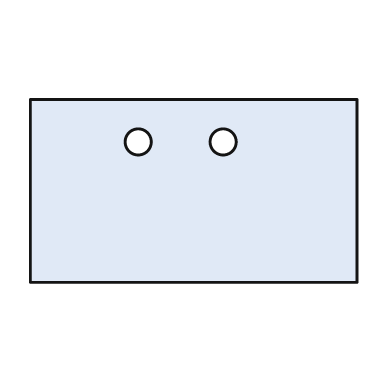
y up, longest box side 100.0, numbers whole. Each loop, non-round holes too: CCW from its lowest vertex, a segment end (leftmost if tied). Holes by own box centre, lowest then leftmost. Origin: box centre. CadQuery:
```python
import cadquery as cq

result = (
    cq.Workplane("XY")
    .moveTo(-50.0, -28.0)
    .lineTo(50.0, -28.0)
    .lineTo(50.0, 28.0)
    .lineTo(-50.0, 28.0)
    .close()
    .moveTo(-17.0, 15.0)
    .circle(4.0)
    .moveTo(9.0, 15.0)
    .circle(4.0)
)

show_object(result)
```